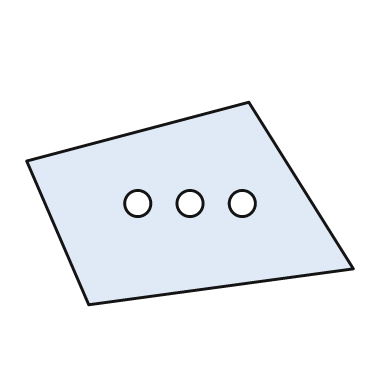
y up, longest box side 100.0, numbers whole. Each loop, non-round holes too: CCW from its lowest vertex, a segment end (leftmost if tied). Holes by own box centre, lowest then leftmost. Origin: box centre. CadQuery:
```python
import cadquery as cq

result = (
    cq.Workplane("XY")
    .moveTo(-31.0, -31.0)
    .lineTo(50.0, -20.0)
    .lineTo(18.0, 31.0)
    .lineTo(-50.0, 13.0)
    .close()
    .moveTo(-16.0, 0.0)
    .circle(4.0)
    .moveTo(0.0, 0.0)
    .circle(4.0)
    .moveTo(16.0, 0.0)
    .circle(4.0)
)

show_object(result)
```